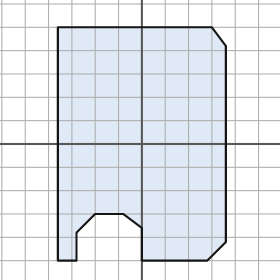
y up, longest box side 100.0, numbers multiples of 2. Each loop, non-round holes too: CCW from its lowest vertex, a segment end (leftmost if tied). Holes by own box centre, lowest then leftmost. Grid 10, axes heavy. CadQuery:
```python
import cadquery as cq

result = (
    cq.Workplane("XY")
    .moveTo(-36.0, -50.0)
    .lineTo(-28.0, -50.0)
    .lineTo(-28.0, -38.0)
    .lineTo(-20.0, -30.0)
    .lineTo(-8.0, -30.0)
    .lineTo(0.0, -36.0)
    .lineTo(0.0, -50.0)
    .lineTo(28.0, -50.0)
    .lineTo(36.0, -42.0)
    .lineTo(36.0, 42.0)
    .lineTo(30.0, 50.0)
    .lineTo(-36.0, 50.0)
    .close()
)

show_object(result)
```